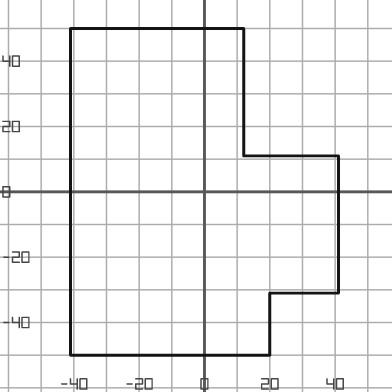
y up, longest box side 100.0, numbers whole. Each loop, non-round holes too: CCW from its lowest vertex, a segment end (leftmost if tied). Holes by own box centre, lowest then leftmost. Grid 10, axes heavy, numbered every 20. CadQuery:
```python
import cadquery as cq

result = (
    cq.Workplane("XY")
    .moveTo(-41.0, -50.0)
    .lineTo(20.0, -50.0)
    .lineTo(20.0, -31.0)
    .lineTo(41.0, -31.0)
    .lineTo(41.0, 11.0)
    .lineTo(12.0, 11.0)
    .lineTo(12.0, 50.0)
    .lineTo(-41.0, 50.0)
    .close()
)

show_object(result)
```